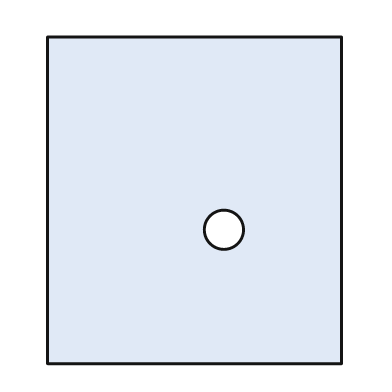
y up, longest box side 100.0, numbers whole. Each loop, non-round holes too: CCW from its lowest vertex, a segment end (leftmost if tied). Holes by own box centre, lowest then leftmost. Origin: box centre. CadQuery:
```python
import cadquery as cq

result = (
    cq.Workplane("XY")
    .moveTo(-45.0, -50.0)
    .lineTo(45.0, -50.0)
    .lineTo(45.0, 50.0)
    .lineTo(-45.0, 50.0)
    .close()
    .moveTo(9.0, -9.0)
    .circle(6.0)
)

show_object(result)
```